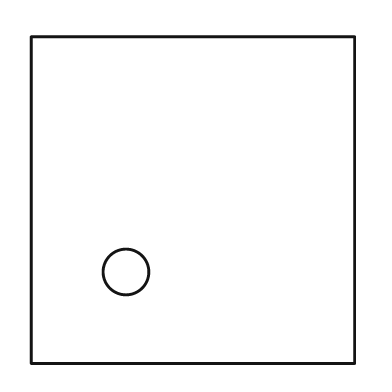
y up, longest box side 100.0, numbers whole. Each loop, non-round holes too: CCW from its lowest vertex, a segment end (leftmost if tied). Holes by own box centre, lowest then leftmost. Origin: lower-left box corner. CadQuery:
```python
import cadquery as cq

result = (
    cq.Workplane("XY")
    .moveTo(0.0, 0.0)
    .lineTo(99.0, 0.0)
    .lineTo(99.0, 100.0)
    .lineTo(0.0, 100.0)
    .close()
    .moveTo(29.0, 28.0)
    .circle(7.0)
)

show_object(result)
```